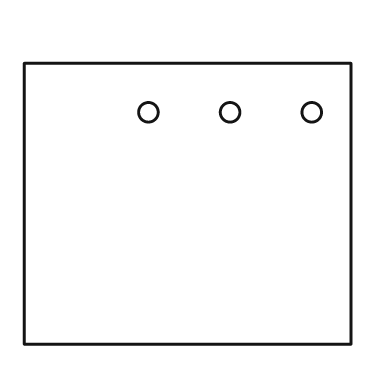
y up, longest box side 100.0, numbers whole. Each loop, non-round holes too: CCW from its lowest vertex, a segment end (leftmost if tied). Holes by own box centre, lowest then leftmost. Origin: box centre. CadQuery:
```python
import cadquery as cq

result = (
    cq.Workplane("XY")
    .moveTo(-50.0, -43.0)
    .lineTo(50.0, -43.0)
    .lineTo(50.0, 43.0)
    .lineTo(-50.0, 43.0)
    .close()
    .moveTo(-12.0, 28.0)
    .circle(3.0)
    .moveTo(13.0, 28.0)
    .circle(3.0)
    .moveTo(38.0, 28.0)
    .circle(3.0)
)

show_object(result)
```